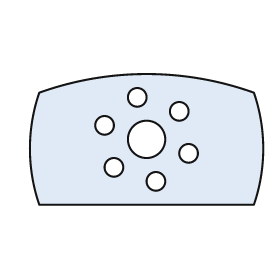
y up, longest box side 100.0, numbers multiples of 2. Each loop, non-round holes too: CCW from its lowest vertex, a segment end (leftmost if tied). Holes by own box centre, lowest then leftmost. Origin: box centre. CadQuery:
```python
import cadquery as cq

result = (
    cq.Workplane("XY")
    .moveTo(-46.0, -28.0)
    .lineTo(46.0, -28.0)
    .threePointArc((50.0, -4.0), (46.0, 20.0))
    .threePointArc((0.0, 28.0), (-46.0, 20.0))
    .threePointArc((-50.0, -4.0), (-46.0, -28.0))
    .close()
    .moveTo(4.0, -18.0)
    .circle(4.0)
    .moveTo(-14.0, -12.0)
    .circle(4.0)
    .moveTo(18.0, -6.0)
    .circle(4.0)
    .moveTo(0.0, 0.0)
    .circle(8.0)
    .moveTo(-18.0, 6.0)
    .circle(4.0)
    .moveTo(14.0, 12.0)
    .circle(4.0)
    .moveTo(-4.0, 18.0)
    .circle(4.0)
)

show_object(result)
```